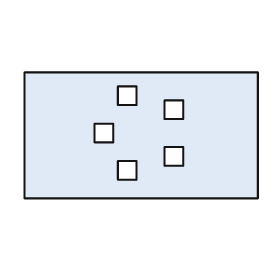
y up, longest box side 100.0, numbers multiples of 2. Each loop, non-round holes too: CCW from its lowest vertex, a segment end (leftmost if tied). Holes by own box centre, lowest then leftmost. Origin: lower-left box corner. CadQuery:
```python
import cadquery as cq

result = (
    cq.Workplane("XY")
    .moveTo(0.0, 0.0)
    .lineTo(100.0, 0.0)
    .lineTo(100.0, 54.0)
    .lineTo(0.0, 54.0)
    .close()
    .moveTo(40.0, 8.0)
    .lineTo(48.0, 8.0)
    .lineTo(48.0, 16.0)
    .lineTo(40.0, 16.0)
    .close()
    .moveTo(60.0, 14.0)
    .lineTo(68.0, 14.0)
    .lineTo(68.0, 22.0)
    .lineTo(60.0, 22.0)
    .close()
    .moveTo(30.0, 24.0)
    .lineTo(38.0, 24.0)
    .lineTo(38.0, 32.0)
    .lineTo(30.0, 32.0)
    .close()
    .moveTo(60.0, 34.0)
    .lineTo(68.0, 34.0)
    .lineTo(68.0, 42.0)
    .lineTo(60.0, 42.0)
    .close()
    .moveTo(40.0, 40.0)
    .lineTo(48.0, 40.0)
    .lineTo(48.0, 48.0)
    .lineTo(40.0, 48.0)
    .close()
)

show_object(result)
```